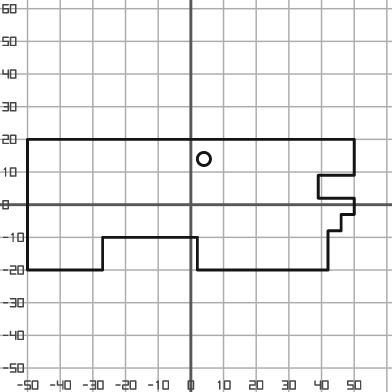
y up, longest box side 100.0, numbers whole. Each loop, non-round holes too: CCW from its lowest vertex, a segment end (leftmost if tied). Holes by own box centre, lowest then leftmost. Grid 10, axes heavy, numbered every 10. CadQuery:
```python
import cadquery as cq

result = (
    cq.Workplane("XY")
    .moveTo(-50.0, -20.0)
    .lineTo(-27.0, -20.0)
    .lineTo(-27.0, -10.0)
    .lineTo(2.0, -10.0)
    .lineTo(2.0, -20.0)
    .lineTo(42.0, -20.0)
    .lineTo(42.0, -8.0)
    .lineTo(46.0, -8.0)
    .lineTo(46.0, -3.0)
    .lineTo(50.0, -3.0)
    .lineTo(50.0, 2.0)
    .lineTo(39.0, 2.0)
    .lineTo(39.0, 9.0)
    .lineTo(50.0, 9.0)
    .lineTo(50.0, 20.0)
    .lineTo(-50.0, 20.0)
    .close()
    .moveTo(4.0, 14.0)
    .circle(2.0)
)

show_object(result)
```